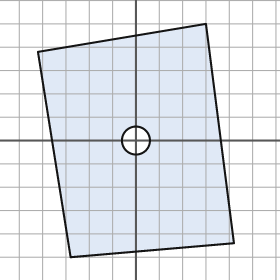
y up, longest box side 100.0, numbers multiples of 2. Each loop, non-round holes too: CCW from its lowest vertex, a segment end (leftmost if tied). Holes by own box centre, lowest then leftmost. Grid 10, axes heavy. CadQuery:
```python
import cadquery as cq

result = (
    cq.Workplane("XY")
    .moveTo(-28.0, -50.0)
    .lineTo(42.0, -44.0)
    .lineTo(30.0, 50.0)
    .lineTo(-42.0, 38.0)
    .close()
    .moveTo(0.0, 0.0)
    .circle(6.0)
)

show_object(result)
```